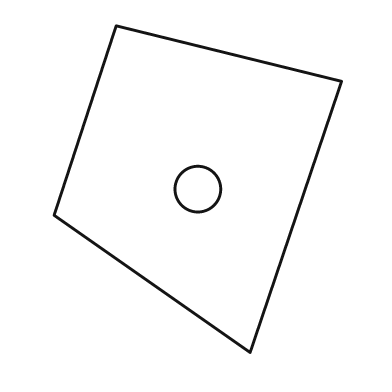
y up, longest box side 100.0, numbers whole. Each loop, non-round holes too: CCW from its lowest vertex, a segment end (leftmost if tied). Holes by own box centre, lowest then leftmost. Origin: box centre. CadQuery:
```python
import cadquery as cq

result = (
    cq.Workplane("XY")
    .moveTo(16.0, -50.0)
    .lineTo(44.0, 33.0)
    .lineTo(-25.0, 50.0)
    .lineTo(-44.0, -8.0)
    .close()
    .moveTo(0.0, 0.0)
    .circle(7.0)
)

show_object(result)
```